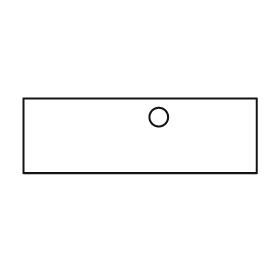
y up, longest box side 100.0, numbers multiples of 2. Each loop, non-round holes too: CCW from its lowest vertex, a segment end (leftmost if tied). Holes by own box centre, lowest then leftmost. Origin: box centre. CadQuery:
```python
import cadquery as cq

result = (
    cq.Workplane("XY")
    .moveTo(-50.0, -16.0)
    .lineTo(50.0, -16.0)
    .lineTo(50.0, 16.0)
    .lineTo(-50.0, 16.0)
    .close()
    .moveTo(8.0, 8.0)
    .circle(4.0)
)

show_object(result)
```